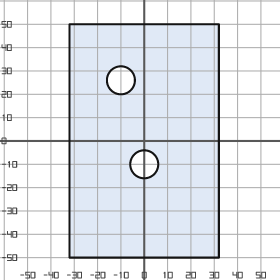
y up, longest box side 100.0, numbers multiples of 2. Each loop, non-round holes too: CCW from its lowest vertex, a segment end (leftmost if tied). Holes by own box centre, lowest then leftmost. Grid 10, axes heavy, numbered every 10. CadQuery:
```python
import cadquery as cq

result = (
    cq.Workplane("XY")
    .moveTo(-32.0, -50.0)
    .lineTo(32.0, -50.0)
    .lineTo(32.0, 50.0)
    .lineTo(-32.0, 50.0)
    .close()
    .moveTo(0.0, -10.0)
    .circle(6.0)
    .moveTo(-10.0, 26.0)
    .circle(6.0)
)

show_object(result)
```